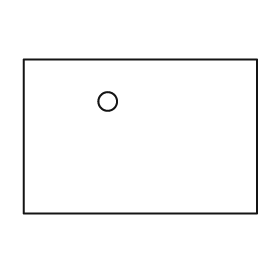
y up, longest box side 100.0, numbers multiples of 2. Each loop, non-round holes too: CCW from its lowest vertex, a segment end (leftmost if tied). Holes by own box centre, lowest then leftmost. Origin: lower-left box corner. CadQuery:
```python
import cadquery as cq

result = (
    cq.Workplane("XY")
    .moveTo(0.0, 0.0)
    .lineTo(100.0, 0.0)
    .lineTo(100.0, 66.0)
    .lineTo(0.0, 66.0)
    .close()
    .moveTo(36.0, 48.0)
    .circle(4.0)
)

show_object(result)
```